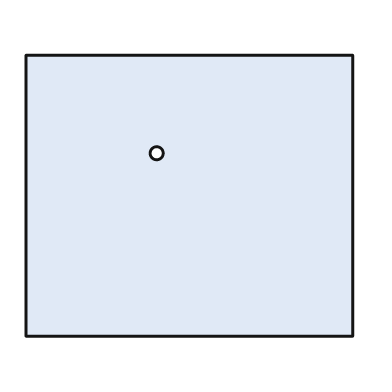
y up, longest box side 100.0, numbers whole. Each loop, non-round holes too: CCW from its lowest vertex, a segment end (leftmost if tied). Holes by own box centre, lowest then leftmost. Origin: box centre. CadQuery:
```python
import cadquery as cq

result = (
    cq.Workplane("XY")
    .moveTo(-50.0, -43.0)
    .lineTo(50.0, -43.0)
    .lineTo(50.0, 43.0)
    .lineTo(-50.0, 43.0)
    .close()
    .moveTo(-10.0, 13.0)
    .circle(2.0)
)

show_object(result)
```